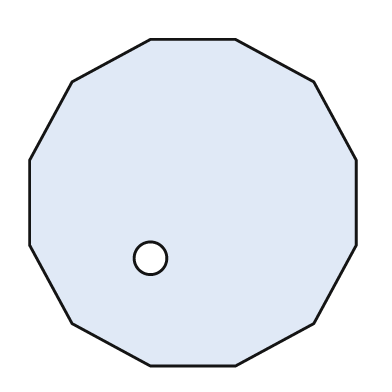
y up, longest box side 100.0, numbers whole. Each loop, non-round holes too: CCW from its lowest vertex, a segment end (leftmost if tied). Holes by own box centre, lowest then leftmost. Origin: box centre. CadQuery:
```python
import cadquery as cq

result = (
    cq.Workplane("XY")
    .moveTo(-13.0, -50.0)
    .lineTo(13.0, -50.0)
    .lineTo(37.0, -37.0)
    .lineTo(50.0, -13.0)
    .lineTo(50.0, 13.0)
    .lineTo(37.0, 37.0)
    .lineTo(13.0, 50.0)
    .lineTo(-13.0, 50.0)
    .lineTo(-37.0, 37.0)
    .lineTo(-50.0, 13.0)
    .lineTo(-50.0, -13.0)
    .lineTo(-37.0, -37.0)
    .close()
    .moveTo(-13.0, -17.0)
    .circle(5.0)
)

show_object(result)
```